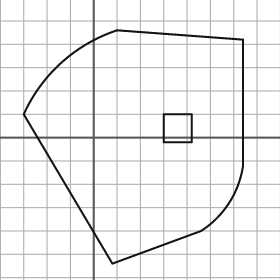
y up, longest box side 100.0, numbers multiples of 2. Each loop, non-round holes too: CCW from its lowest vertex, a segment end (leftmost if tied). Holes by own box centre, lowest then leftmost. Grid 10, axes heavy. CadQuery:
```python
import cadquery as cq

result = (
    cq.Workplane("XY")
    .moveTo(8.0, -54.0)
    .lineTo(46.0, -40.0)
    .threePointArc((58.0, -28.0), (64.0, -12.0))
    .lineTo(64.0, 42.0)
    .lineTo(10.0, 46.0)
    .threePointArc((-14.0, 32.0), (-30.0, 10.0))
    .close()
    .moveTo(30.0, -2.0)
    .lineTo(42.0, -2.0)
    .lineTo(42.0, 10.0)
    .lineTo(30.0, 10.0)
    .close()
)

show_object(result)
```